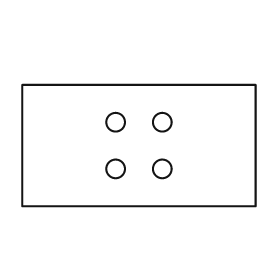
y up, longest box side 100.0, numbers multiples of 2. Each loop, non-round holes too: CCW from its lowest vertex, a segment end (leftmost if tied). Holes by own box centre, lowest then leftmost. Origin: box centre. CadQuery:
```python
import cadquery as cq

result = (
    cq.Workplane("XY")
    .moveTo(-50.0, -26.0)
    .lineTo(50.0, -26.0)
    .lineTo(50.0, 26.0)
    .lineTo(-50.0, 26.0)
    .close()
    .moveTo(-10.0, -10.0)
    .circle(4.0)
    .moveTo(10.0, -10.0)
    .circle(4.0)
    .moveTo(-10.0, 10.0)
    .circle(4.0)
    .moveTo(10.0, 10.0)
    .circle(4.0)
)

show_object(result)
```